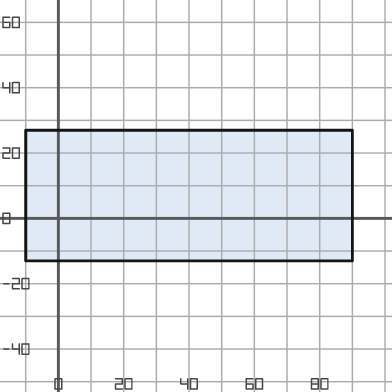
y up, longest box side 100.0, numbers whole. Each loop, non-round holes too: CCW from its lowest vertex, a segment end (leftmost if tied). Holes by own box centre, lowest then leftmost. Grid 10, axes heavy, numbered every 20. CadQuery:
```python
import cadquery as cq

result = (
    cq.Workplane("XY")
    .moveTo(-10.0, -13.0)
    .lineTo(90.0, -13.0)
    .lineTo(90.0, 27.0)
    .lineTo(-10.0, 27.0)
    .close()
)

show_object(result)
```